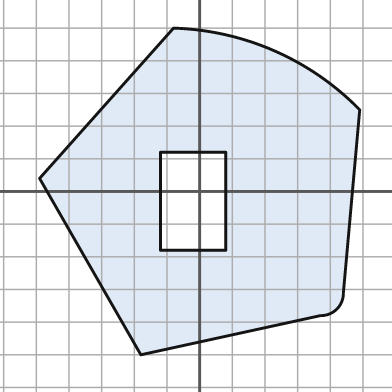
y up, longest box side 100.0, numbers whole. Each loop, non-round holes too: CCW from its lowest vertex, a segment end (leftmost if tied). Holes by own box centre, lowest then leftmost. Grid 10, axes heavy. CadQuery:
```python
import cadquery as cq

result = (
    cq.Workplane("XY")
    .moveTo(-18.0, -50.0)
    .lineTo(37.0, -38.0)
    .threePointArc((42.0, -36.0), (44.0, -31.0))
    .lineTo(49.0, 25.0)
    .threePointArc((23.0, 43.0), (-8.0, 50.0))
    .lineTo(-49.0, 4.0)
    .close()
    .moveTo(-12.0, -18.0)
    .lineTo(8.0, -18.0)
    .lineTo(8.0, 12.0)
    .lineTo(-12.0, 12.0)
    .close()
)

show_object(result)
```